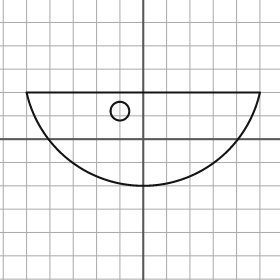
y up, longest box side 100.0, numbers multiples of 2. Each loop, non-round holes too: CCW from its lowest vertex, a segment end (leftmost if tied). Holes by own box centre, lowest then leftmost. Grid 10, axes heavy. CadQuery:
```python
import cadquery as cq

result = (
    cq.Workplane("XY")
    .moveTo(-50.0, 20.0)
    .threePointArc((0.0, -20.0), (50.0, 20.0))
    .close()
    .moveTo(-10.0, 12.0)
    .circle(4.0)
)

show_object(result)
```